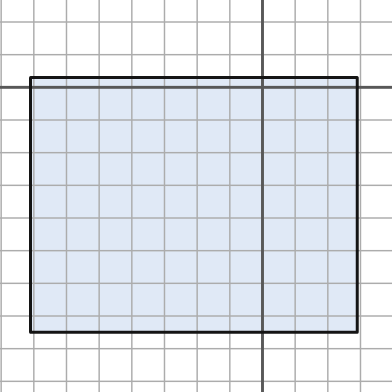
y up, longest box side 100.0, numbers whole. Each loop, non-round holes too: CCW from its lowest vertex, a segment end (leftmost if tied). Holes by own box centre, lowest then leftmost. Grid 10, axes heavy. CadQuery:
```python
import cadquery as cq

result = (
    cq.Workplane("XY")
    .moveTo(-71.0, -75.0)
    .lineTo(29.0, -75.0)
    .lineTo(29.0, 3.0)
    .lineTo(-71.0, 3.0)
    .close()
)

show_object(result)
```